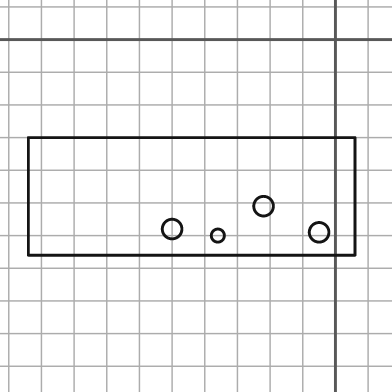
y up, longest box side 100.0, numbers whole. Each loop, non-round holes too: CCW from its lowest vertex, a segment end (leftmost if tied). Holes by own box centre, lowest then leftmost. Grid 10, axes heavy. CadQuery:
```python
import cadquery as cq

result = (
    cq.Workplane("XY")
    .moveTo(-94.0, -66.0)
    .lineTo(6.0, -66.0)
    .lineTo(6.0, -30.0)
    .lineTo(-94.0, -30.0)
    .close()
    .moveTo(-36.0, -60.0)
    .circle(2.0)
    .moveTo(-5.0, -59.0)
    .circle(3.0)
    .moveTo(-50.0, -58.0)
    .circle(3.0)
    .moveTo(-22.0, -51.0)
    .circle(3.0)
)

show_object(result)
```